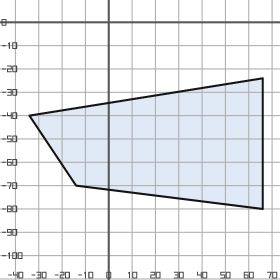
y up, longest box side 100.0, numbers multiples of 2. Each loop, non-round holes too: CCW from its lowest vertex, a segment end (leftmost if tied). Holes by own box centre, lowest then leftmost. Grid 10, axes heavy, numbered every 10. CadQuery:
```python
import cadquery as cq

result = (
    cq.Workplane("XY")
    .moveTo(66.0, -80.0)
    .lineTo(66.0, -24.0)
    .lineTo(-34.0, -40.0)
    .lineTo(-14.0, -70.0)
    .close()
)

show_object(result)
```